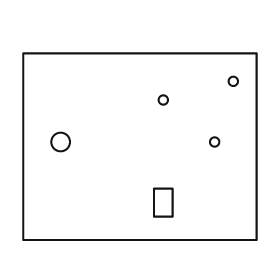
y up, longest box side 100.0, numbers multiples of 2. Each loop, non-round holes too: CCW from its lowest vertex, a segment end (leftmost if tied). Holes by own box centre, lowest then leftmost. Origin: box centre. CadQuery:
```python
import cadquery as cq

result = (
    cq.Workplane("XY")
    .moveTo(-50.0, -40.0)
    .lineTo(50.0, -40.0)
    .lineTo(50.0, 40.0)
    .lineTo(-50.0, 40.0)
    .close()
    .moveTo(6.0, -30.0)
    .lineTo(14.0, -30.0)
    .lineTo(14.0, -18.0)
    .lineTo(6.0, -18.0)
    .close()
    .moveTo(-34.0, 2.0)
    .circle(4.0)
    .moveTo(32.0, 2.0)
    .circle(2.0)
    .moveTo(10.0, 20.0)
    .circle(2.0)
    .moveTo(40.0, 28.0)
    .circle(2.0)
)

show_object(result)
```